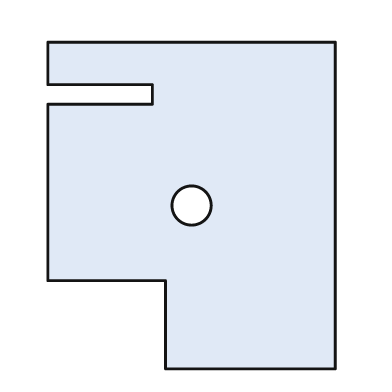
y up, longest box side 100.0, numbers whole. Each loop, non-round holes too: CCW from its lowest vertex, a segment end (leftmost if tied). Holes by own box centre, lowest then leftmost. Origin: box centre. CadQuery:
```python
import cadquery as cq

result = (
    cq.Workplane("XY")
    .moveTo(-8.0, -50.0)
    .lineTo(44.0, -50.0)
    .lineTo(44.0, 50.0)
    .lineTo(-44.0, 50.0)
    .lineTo(-44.0, 37.0)
    .lineTo(-12.0, 37.0)
    .lineTo(-12.0, 31.0)
    .lineTo(-44.0, 31.0)
    .lineTo(-44.0, -23.0)
    .lineTo(-8.0, -23.0)
    .close()
    .moveTo(0.0, 0.0)
    .circle(6.0)
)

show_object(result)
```